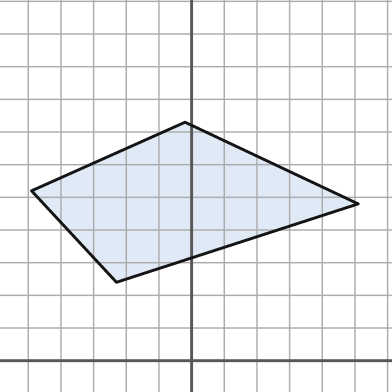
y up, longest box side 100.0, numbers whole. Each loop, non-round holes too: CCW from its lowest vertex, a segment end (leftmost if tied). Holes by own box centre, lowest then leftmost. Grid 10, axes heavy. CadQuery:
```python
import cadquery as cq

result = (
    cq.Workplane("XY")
    .moveTo(-23.0, 24.0)
    .lineTo(51.0, 48.0)
    .lineTo(-2.0, 73.0)
    .lineTo(-49.0, 52.0)
    .close()
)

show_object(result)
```